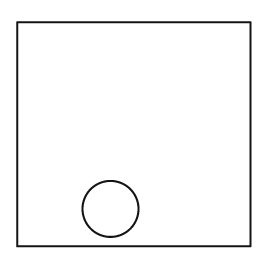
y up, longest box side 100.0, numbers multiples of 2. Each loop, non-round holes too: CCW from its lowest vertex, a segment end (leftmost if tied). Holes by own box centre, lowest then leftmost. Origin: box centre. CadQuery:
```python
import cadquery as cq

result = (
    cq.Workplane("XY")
    .moveTo(-50.0, -48.0)
    .lineTo(50.0, -48.0)
    .lineTo(50.0, 48.0)
    .lineTo(-50.0, 48.0)
    .close()
    .moveTo(-10.0, -32.0)
    .circle(12.0)
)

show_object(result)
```